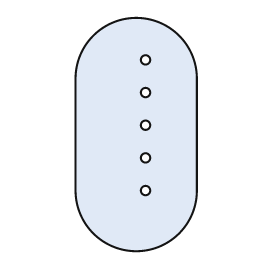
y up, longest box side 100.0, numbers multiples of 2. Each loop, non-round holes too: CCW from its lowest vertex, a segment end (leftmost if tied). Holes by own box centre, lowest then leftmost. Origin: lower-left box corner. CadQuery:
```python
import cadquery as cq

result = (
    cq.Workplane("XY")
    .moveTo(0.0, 26.0)
    .threePointArc((26.0, 0.0), (52.0, 26.0))
    .lineTo(52.0, 74.0)
    .threePointArc((26.0, 100.0), (0.0, 74.0))
    .close()
    .moveTo(30.0, 26.0)
    .circle(2.0)
    .moveTo(30.0, 40.0)
    .circle(2.0)
    .moveTo(30.0, 54.0)
    .circle(2.0)
    .moveTo(30.0, 68.0)
    .circle(2.0)
    .moveTo(30.0, 82.0)
    .circle(2.0)
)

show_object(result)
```